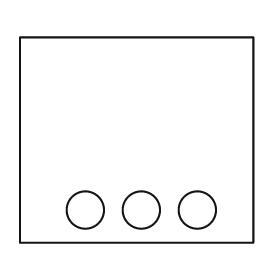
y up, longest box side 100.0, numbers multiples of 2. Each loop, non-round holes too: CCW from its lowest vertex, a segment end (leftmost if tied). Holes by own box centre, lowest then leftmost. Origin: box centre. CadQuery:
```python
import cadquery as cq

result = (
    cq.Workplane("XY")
    .moveTo(-50.0, -44.0)
    .lineTo(50.0, -44.0)
    .lineTo(50.0, 44.0)
    .lineTo(-50.0, 44.0)
    .close()
    .moveTo(-22.0, -30.0)
    .circle(8.0)
    .moveTo(2.0, -30.0)
    .circle(8.0)
    .moveTo(26.0, -30.0)
    .circle(8.0)
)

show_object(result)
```